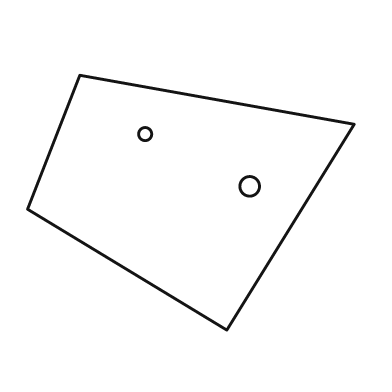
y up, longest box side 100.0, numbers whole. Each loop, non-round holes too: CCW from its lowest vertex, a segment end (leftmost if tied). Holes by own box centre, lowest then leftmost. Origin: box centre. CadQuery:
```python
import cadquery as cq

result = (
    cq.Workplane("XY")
    .moveTo(11.0, -39.0)
    .lineTo(50.0, 24.0)
    .lineTo(-34.0, 39.0)
    .lineTo(-50.0, -2.0)
    .close()
    .moveTo(18.0, 5.0)
    .circle(3.0)
    .moveTo(-14.0, 21.0)
    .circle(2.0)
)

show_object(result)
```